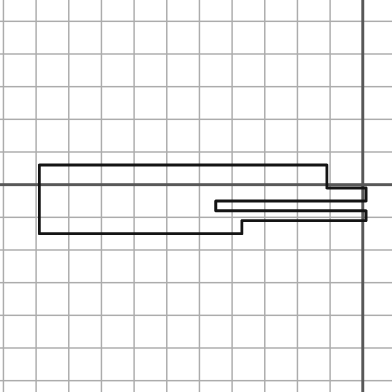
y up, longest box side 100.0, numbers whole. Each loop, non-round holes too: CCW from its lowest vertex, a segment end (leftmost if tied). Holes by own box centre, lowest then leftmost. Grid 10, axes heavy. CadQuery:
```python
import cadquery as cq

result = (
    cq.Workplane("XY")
    .moveTo(-99.0, -15.0)
    .lineTo(-37.0, -15.0)
    .lineTo(-37.0, -11.0)
    .lineTo(1.0, -11.0)
    .lineTo(1.0, -8.0)
    .lineTo(-45.0, -8.0)
    .lineTo(-45.0, -5.0)
    .lineTo(1.0, -5.0)
    .lineTo(1.0, -1.0)
    .lineTo(-11.0, -1.0)
    .lineTo(-11.0, 6.0)
    .lineTo(-99.0, 6.0)
    .close()
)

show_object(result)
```